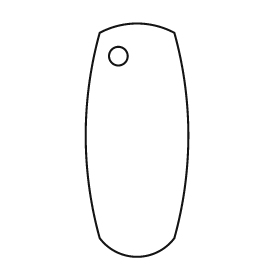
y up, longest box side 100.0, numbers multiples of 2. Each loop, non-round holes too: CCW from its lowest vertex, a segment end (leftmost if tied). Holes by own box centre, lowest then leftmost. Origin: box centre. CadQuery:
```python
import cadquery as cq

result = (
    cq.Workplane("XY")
    .moveTo(-16.0, -42.0)
    .threePointArc((0.0, -50.0), (16.0, -42.0))
    .threePointArc((22.0, 2.0), (16.0, 46.0))
    .threePointArc((0.0, 50.0), (-16.0, 46.0))
    .threePointArc((-22.0, 2.0), (-16.0, -42.0))
    .close()
    .moveTo(-8.0, 36.0)
    .circle(4.0)
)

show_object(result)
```